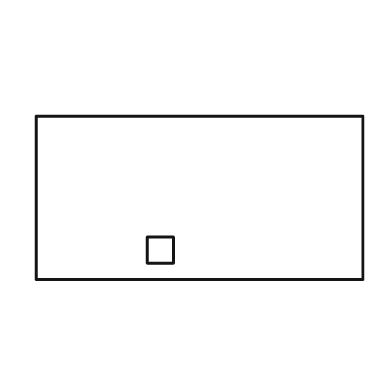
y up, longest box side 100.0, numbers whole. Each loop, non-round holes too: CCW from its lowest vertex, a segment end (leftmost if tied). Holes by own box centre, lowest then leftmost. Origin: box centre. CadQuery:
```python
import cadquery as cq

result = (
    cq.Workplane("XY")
    .moveTo(-50.0, -25.0)
    .lineTo(50.0, -25.0)
    .lineTo(50.0, 25.0)
    .lineTo(-50.0, 25.0)
    .close()
    .moveTo(-16.0, -20.0)
    .lineTo(-8.0, -20.0)
    .lineTo(-8.0, -12.0)
    .lineTo(-16.0, -12.0)
    .close()
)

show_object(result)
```